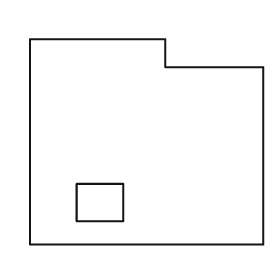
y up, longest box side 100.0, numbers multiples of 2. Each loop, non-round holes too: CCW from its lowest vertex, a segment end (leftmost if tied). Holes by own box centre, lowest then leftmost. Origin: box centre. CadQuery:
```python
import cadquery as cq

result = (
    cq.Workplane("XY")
    .moveTo(-50.0, -44.0)
    .lineTo(50.0, -44.0)
    .lineTo(50.0, 32.0)
    .lineTo(8.0, 32.0)
    .lineTo(8.0, 44.0)
    .lineTo(-50.0, 44.0)
    .close()
    .moveTo(-30.0, -34.0)
    .lineTo(-10.0, -34.0)
    .lineTo(-10.0, -18.0)
    .lineTo(-30.0, -18.0)
    .close()
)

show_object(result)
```